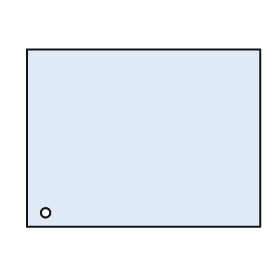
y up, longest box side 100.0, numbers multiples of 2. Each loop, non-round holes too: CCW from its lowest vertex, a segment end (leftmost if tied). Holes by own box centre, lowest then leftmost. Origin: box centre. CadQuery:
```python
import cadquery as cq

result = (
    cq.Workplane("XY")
    .moveTo(-50.0, -38.0)
    .lineTo(50.0, -38.0)
    .lineTo(50.0, 38.0)
    .lineTo(-50.0, 38.0)
    .close()
    .moveTo(-42.0, -32.0)
    .circle(2.0)
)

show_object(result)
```